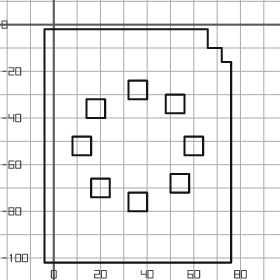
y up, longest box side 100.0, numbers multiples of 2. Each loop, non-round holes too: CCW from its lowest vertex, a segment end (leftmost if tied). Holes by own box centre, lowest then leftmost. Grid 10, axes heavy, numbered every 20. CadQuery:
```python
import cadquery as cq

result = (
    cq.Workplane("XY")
    .moveTo(-4.0, -102.0)
    .lineTo(76.0, -102.0)
    .lineTo(76.0, -16.0)
    .lineTo(72.0, -16.0)
    .lineTo(72.0, -10.0)
    .lineTo(66.0, -10.0)
    .lineTo(66.0, -2.0)
    .lineTo(-4.0, -2.0)
    .close()
    .moveTo(32.0, -80.0)
    .lineTo(40.0, -80.0)
    .lineTo(40.0, -72.0)
    .lineTo(32.0, -72.0)
    .close()
    .moveTo(16.0, -74.0)
    .lineTo(24.0, -74.0)
    .lineTo(24.0, -66.0)
    .lineTo(16.0, -66.0)
    .close()
    .moveTo(50.0, -72.0)
    .lineTo(58.0, -72.0)
    .lineTo(58.0, -64.0)
    .lineTo(50.0, -64.0)
    .close()
    .moveTo(8.0, -56.0)
    .lineTo(16.0, -56.0)
    .lineTo(16.0, -48.0)
    .lineTo(8.0, -48.0)
    .close()
    .moveTo(56.0, -56.0)
    .lineTo(64.0, -56.0)
    .lineTo(64.0, -48.0)
    .lineTo(56.0, -48.0)
    .close()
    .moveTo(14.0, -40.0)
    .lineTo(22.0, -40.0)
    .lineTo(22.0, -32.0)
    .lineTo(14.0, -32.0)
    .close()
    .moveTo(48.0, -38.0)
    .lineTo(56.0, -38.0)
    .lineTo(56.0, -30.0)
    .lineTo(48.0, -30.0)
    .close()
    .moveTo(32.0, -32.0)
    .lineTo(40.0, -32.0)
    .lineTo(40.0, -24.0)
    .lineTo(32.0, -24.0)
    .close()
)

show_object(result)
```